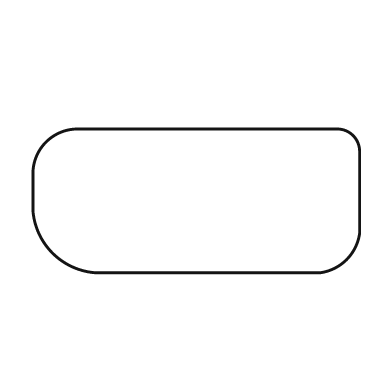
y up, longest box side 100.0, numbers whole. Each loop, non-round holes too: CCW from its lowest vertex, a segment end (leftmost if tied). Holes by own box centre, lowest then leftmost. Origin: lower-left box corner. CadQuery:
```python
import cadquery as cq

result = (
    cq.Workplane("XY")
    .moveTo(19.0, 0.0)
    .lineTo(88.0, 0.0)
    .threePointArc((96.0, 4.0), (100.0, 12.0))
    .lineTo(100.0, 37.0)
    .threePointArc((98.0, 42.0), (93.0, 44.0))
    .lineTo(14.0, 44.0)
    .threePointArc((4.0, 40.0), (0.0, 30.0))
    .lineTo(0.0, 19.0)
    .threePointArc((6.0, 6.0), (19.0, 0.0))
    .close()
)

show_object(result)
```